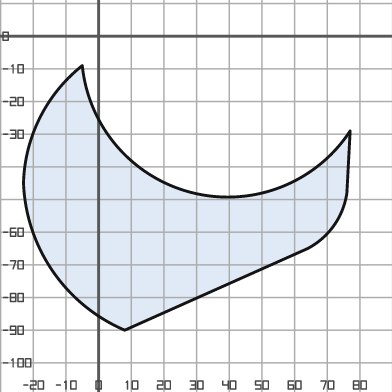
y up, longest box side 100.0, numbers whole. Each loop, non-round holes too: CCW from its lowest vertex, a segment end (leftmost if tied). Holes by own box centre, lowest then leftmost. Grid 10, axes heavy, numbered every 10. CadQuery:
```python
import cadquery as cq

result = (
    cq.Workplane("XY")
    .moveTo(8.0, -90.0)
    .lineTo(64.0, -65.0)
    .threePointArc((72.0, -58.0), (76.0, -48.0))
    .lineTo(77.0, -29.0)
    .threePointArc((29.0, -48.0), (-5.0, -9.0))
    .threePointArc((-18.0, -25.0), (-23.0, -45.0))
    .threePointArc((-14.0, -72.0), (8.0, -90.0))
    .close()
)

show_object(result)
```